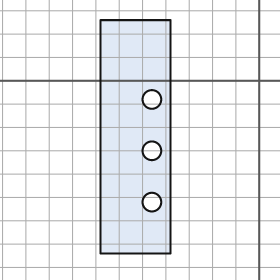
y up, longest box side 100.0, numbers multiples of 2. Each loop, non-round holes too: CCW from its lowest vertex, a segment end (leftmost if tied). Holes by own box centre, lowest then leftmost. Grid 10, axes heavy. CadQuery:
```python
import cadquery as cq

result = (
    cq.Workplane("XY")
    .moveTo(-68.0, -74.0)
    .lineTo(-38.0, -74.0)
    .lineTo(-38.0, 26.0)
    .lineTo(-68.0, 26.0)
    .close()
    .moveTo(-46.0, -52.0)
    .circle(4.0)
    .moveTo(-46.0, -30.0)
    .circle(4.0)
    .moveTo(-46.0, -8.0)
    .circle(4.0)
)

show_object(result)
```